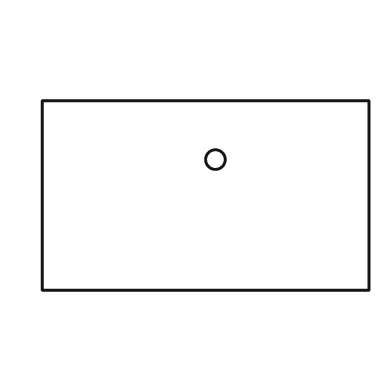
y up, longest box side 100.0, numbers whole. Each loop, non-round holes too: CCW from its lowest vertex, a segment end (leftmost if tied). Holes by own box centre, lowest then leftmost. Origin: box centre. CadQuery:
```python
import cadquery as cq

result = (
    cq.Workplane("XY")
    .moveTo(-50.0, -29.0)
    .lineTo(50.0, -29.0)
    .lineTo(50.0, 29.0)
    .lineTo(-50.0, 29.0)
    .close()
    .moveTo(3.0, 11.0)
    .circle(3.0)
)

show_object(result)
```